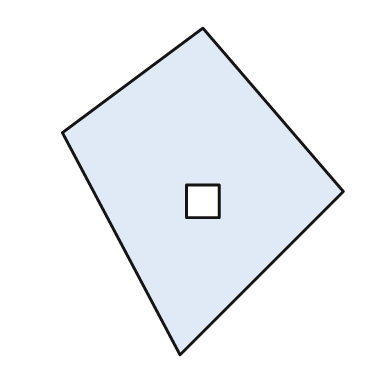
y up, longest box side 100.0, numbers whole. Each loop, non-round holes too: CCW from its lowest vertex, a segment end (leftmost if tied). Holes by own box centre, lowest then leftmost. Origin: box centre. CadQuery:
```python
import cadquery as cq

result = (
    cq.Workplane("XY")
    .moveTo(-7.0, -50.0)
    .lineTo(43.0, 0.0)
    .lineTo(0.0, 50.0)
    .lineTo(-43.0, 18.0)
    .close()
    .moveTo(-5.0, -8.0)
    .lineTo(5.0, -8.0)
    .lineTo(5.0, 2.0)
    .lineTo(-5.0, 2.0)
    .close()
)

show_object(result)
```